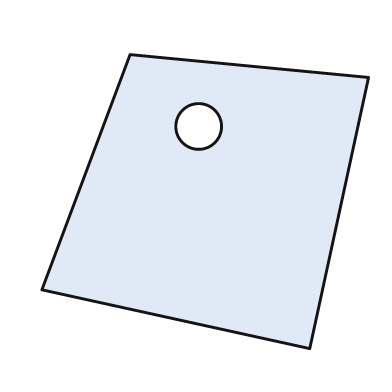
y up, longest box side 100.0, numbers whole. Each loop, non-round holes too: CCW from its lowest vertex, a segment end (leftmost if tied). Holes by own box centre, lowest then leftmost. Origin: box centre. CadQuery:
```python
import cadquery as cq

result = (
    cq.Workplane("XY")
    .moveTo(32.0, -45.0)
    .lineTo(50.0, 38.0)
    .lineTo(-23.0, 45.0)
    .lineTo(-50.0, -27.0)
    .close()
    .moveTo(-2.0, 23.0)
    .circle(7.0)
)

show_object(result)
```